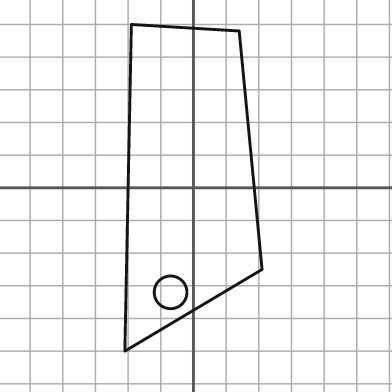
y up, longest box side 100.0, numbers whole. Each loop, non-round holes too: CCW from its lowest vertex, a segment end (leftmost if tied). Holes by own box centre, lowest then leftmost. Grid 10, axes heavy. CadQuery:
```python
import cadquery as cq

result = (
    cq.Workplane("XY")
    .moveTo(-21.0, -50.0)
    .lineTo(21.0, -25.0)
    .lineTo(14.0, 48.0)
    .lineTo(-19.0, 50.0)
    .close()
    .moveTo(-7.0, -32.0)
    .circle(5.0)
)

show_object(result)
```